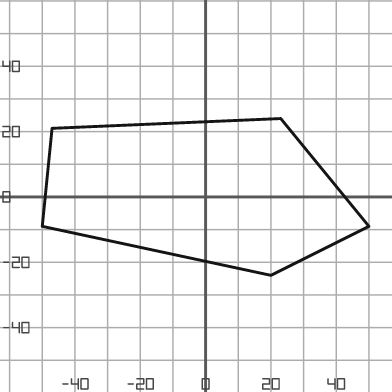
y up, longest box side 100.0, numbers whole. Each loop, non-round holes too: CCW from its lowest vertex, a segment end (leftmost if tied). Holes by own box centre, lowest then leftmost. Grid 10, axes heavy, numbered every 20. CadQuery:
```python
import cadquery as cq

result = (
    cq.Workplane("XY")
    .moveTo(20.0, -24.0)
    .lineTo(50.0, -9.0)
    .lineTo(23.0, 24.0)
    .lineTo(-47.0, 21.0)
    .lineTo(-50.0, -9.0)
    .close()
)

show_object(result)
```